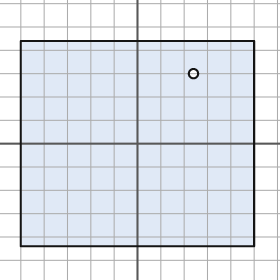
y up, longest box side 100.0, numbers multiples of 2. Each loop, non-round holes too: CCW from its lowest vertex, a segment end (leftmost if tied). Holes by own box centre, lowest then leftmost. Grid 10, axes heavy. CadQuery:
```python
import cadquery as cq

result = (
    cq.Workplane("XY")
    .moveTo(-50.0, -44.0)
    .lineTo(50.0, -44.0)
    .lineTo(50.0, 44.0)
    .lineTo(-50.0, 44.0)
    .close()
    .moveTo(24.0, 30.0)
    .circle(2.0)
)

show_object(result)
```